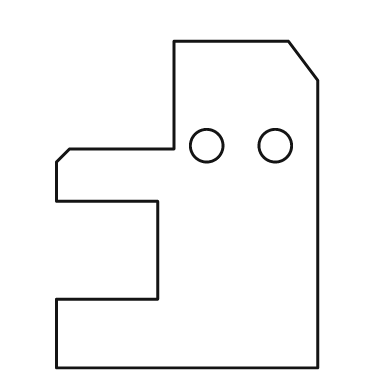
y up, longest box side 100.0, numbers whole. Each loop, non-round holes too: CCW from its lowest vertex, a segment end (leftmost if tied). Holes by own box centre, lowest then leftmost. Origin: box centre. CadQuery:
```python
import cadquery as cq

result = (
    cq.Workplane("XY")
    .moveTo(-40.0, -50.0)
    .lineTo(40.0, -50.0)
    .lineTo(40.0, 38.0)
    .lineTo(31.0, 50.0)
    .lineTo(-4.0, 50.0)
    .lineTo(-4.0, 17.0)
    .lineTo(-36.0, 17.0)
    .lineTo(-40.0, 13.0)
    .lineTo(-40.0, 1.0)
    .lineTo(-9.0, 1.0)
    .lineTo(-9.0, -29.0)
    .lineTo(-40.0, -29.0)
    .close()
    .moveTo(6.0, 18.0)
    .circle(5.0)
    .moveTo(27.0, 18.0)
    .circle(5.0)
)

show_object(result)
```